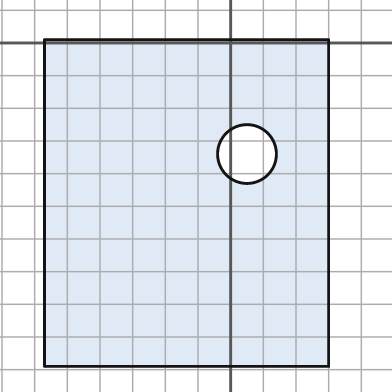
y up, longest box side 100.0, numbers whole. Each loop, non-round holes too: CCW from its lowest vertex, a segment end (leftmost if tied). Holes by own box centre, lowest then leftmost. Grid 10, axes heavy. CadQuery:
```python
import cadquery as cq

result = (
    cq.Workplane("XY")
    .moveTo(-57.0, -99.0)
    .lineTo(30.0, -99.0)
    .lineTo(30.0, 1.0)
    .lineTo(-57.0, 1.0)
    .close()
    .moveTo(5.0, -34.0)
    .circle(9.0)
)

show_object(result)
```